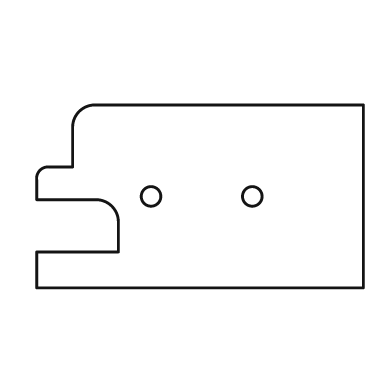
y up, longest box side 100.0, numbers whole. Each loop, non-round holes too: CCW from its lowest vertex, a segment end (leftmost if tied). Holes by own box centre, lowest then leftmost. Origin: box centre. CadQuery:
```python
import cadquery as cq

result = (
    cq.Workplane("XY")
    .moveTo(-50.0, -28.0)
    .lineTo(50.0, -28.0)
    .lineTo(50.0, 28.0)
    .lineTo(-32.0, 28.0)
    .threePointArc((-37.0, 26.0), (-39.0, 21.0))
    .lineTo(-39.0, 9.0)
    .lineTo(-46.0, 9.0)
    .threePointArc((-49.0, 8.0), (-50.0, 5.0))
    .lineTo(-50.0, -1.0)
    .lineTo(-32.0, -1.0)
    .threePointArc((-27.0, -3.0), (-25.0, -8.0))
    .lineTo(-25.0, -17.0)
    .lineTo(-50.0, -17.0)
    .close()
    .moveTo(-15.0, 0.0)
    .circle(3.0)
    .moveTo(16.0, 0.0)
    .circle(3.0)
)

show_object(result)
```